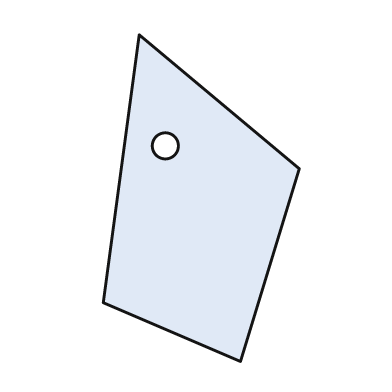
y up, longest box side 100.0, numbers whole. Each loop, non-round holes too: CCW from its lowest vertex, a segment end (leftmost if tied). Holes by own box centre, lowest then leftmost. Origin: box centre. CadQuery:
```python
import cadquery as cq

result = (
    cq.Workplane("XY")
    .moveTo(12.0, -50.0)
    .lineTo(30.0, 9.0)
    .lineTo(-19.0, 50.0)
    .lineTo(-30.0, -32.0)
    .close()
    .moveTo(-11.0, 16.0)
    .circle(4.0)
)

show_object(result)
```